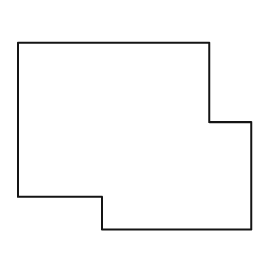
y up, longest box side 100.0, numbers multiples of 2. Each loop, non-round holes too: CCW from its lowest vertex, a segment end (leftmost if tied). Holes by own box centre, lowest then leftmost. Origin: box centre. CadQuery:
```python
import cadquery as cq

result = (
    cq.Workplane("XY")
    .moveTo(-14.0, -40.0)
    .lineTo(50.0, -40.0)
    .lineTo(50.0, 6.0)
    .lineTo(32.0, 6.0)
    .lineTo(32.0, 40.0)
    .lineTo(-50.0, 40.0)
    .lineTo(-50.0, -26.0)
    .lineTo(-14.0, -26.0)
    .close()
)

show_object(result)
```